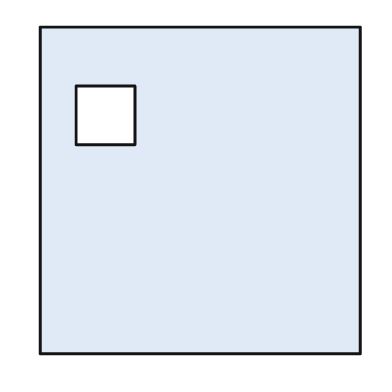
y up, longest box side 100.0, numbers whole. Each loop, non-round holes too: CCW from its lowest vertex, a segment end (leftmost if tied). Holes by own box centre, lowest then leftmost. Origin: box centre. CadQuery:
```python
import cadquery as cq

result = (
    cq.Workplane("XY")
    .moveTo(-49.0, -50.0)
    .lineTo(49.0, -50.0)
    .lineTo(49.0, 50.0)
    .lineTo(-49.0, 50.0)
    .close()
    .moveTo(-38.0, 14.0)
    .lineTo(-20.0, 14.0)
    .lineTo(-20.0, 32.0)
    .lineTo(-38.0, 32.0)
    .close()
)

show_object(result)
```